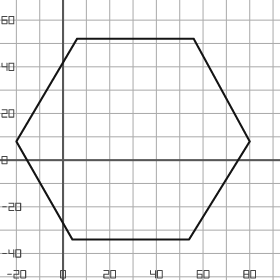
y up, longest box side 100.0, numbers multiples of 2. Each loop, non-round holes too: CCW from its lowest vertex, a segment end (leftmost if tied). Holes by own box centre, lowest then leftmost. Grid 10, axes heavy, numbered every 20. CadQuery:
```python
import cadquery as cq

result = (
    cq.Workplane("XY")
    .moveTo(4.0, -34.0)
    .lineTo(54.0, -34.0)
    .lineTo(80.0, 8.0)
    .lineTo(56.0, 52.0)
    .lineTo(6.0, 52.0)
    .lineTo(-20.0, 8.0)
    .close()
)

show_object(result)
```